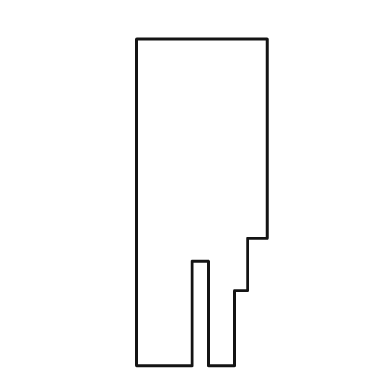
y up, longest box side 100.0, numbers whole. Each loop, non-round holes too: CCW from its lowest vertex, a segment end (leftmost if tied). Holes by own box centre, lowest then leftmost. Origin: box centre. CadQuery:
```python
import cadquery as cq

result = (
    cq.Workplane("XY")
    .moveTo(-20.0, -50.0)
    .lineTo(-3.0, -50.0)
    .lineTo(-3.0, -18.0)
    .lineTo(2.0, -18.0)
    .lineTo(2.0, -50.0)
    .lineTo(10.0, -50.0)
    .lineTo(10.0, -27.0)
    .lineTo(14.0, -27.0)
    .lineTo(14.0, -11.0)
    .lineTo(20.0, -11.0)
    .lineTo(20.0, 50.0)
    .lineTo(-20.0, 50.0)
    .close()
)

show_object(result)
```